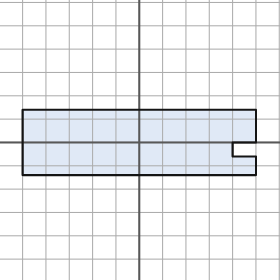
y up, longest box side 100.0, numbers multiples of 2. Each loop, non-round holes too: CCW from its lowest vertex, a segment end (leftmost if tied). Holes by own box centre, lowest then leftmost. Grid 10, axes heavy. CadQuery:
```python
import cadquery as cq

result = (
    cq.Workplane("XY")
    .moveTo(-50.0, -14.0)
    .lineTo(50.0, -14.0)
    .lineTo(50.0, -6.0)
    .lineTo(40.0, -6.0)
    .lineTo(40.0, 0.0)
    .lineTo(50.0, 0.0)
    .lineTo(50.0, 14.0)
    .lineTo(-50.0, 14.0)
    .close()
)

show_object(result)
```